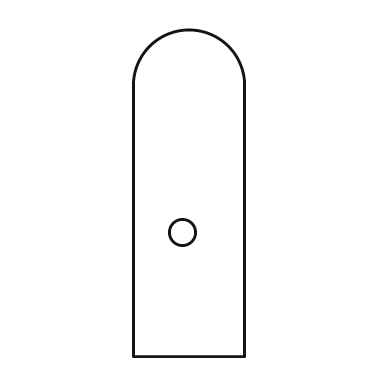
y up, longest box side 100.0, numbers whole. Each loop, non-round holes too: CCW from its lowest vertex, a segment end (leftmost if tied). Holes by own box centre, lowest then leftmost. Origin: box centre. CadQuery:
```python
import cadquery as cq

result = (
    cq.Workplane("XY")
    .moveTo(-17.0, -50.0)
    .lineTo(17.0, -50.0)
    .lineTo(17.0, 34.0)
    .threePointArc((0.0, 50.0), (-17.0, 34.0))
    .close()
    .moveTo(-2.0, -12.0)
    .circle(4.0)
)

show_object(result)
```